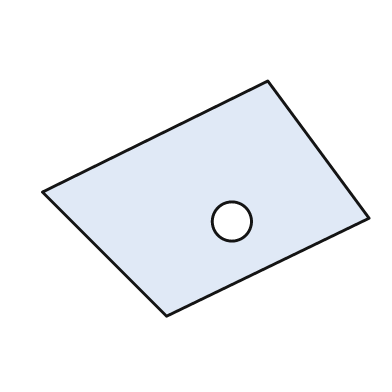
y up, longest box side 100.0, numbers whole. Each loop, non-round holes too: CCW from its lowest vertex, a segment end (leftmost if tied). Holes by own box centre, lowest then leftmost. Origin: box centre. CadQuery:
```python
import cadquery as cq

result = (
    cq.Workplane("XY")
    .moveTo(-12.0, -36.0)
    .lineTo(50.0, -6.0)
    .lineTo(19.0, 36.0)
    .lineTo(-50.0, 2.0)
    .close()
    .moveTo(8.0, -7.0)
    .circle(6.0)
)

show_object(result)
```